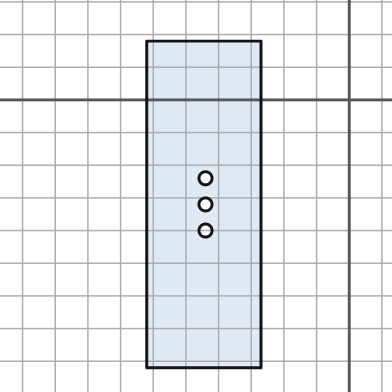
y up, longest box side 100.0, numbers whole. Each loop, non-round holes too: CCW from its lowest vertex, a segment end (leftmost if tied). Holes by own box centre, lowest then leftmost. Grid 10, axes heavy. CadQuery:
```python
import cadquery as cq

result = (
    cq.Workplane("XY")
    .moveTo(-62.0, -82.0)
    .lineTo(-27.0, -82.0)
    .lineTo(-27.0, 18.0)
    .lineTo(-62.0, 18.0)
    .close()
    .moveTo(-44.0, -40.0)
    .circle(2.0)
    .moveTo(-44.0, -32.0)
    .circle(2.0)
    .moveTo(-44.0, -24.0)
    .circle(2.0)
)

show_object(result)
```